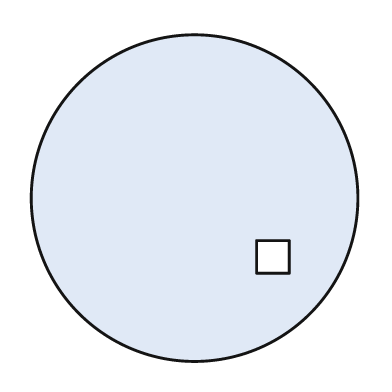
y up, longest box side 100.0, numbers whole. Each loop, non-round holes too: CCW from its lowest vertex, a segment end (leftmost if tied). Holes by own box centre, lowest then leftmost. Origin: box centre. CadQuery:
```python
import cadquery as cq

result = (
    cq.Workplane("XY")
    .moveTo(0.0, 0.0)
    .circle(50.0)
    .moveTo(19.0, -23.0)
    .lineTo(29.0, -23.0)
    .lineTo(29.0, -13.0)
    .lineTo(19.0, -13.0)
    .close()
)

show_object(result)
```